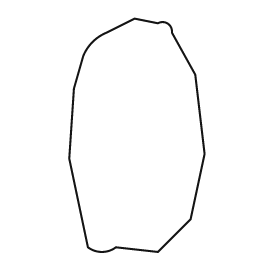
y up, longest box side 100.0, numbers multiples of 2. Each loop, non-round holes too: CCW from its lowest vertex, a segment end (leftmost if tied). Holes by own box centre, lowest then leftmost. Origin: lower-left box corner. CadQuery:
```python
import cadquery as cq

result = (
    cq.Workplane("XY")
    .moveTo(38.0, 0.0)
    .lineTo(52.0, 14.0)
    .lineTo(58.0, 42.0)
    .lineTo(54.0, 76.0)
    .lineTo(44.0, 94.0)
    .threePointArc((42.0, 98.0), (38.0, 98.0))
    .lineTo(28.0, 100.0)
    .lineTo(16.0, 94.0)
    .threePointArc((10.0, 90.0), (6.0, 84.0))
    .lineTo(2.0, 70.0)
    .lineTo(0.0, 40.0)
    .lineTo(8.0, 2.0)
    .threePointArc((14.0, 0.0), (20.0, 2.0))
    .close()
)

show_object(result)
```